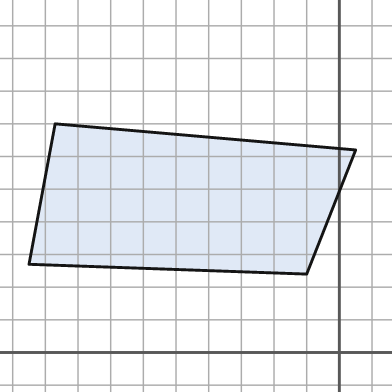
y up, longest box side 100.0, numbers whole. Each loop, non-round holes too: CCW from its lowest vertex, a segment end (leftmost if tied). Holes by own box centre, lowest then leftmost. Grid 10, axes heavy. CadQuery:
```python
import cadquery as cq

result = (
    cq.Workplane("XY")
    .moveTo(-10.0, 24.0)
    .lineTo(5.0, 62.0)
    .lineTo(-87.0, 70.0)
    .lineTo(-95.0, 27.0)
    .close()
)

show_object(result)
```